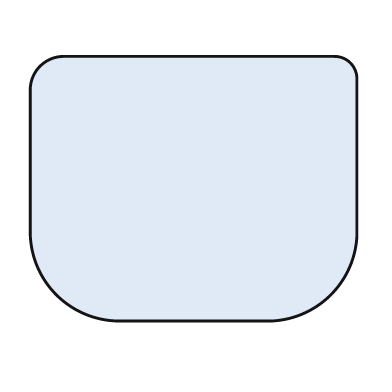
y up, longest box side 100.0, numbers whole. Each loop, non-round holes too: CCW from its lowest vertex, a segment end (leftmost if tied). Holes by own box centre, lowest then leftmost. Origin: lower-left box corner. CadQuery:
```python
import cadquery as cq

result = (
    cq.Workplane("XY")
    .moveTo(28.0, 0.0)
    .lineTo(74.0, 0.0)
    .threePointArc((92.0, 8.0), (100.0, 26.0))
    .lineTo(100.0, 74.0)
    .threePointArc((98.0, 79.0), (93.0, 81.0))
    .lineTo(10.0, 81.0)
    .threePointArc((3.0, 78.0), (0.0, 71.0))
    .lineTo(0.0, 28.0)
    .threePointArc((8.0, 8.0), (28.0, 0.0))
    .close()
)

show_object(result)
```